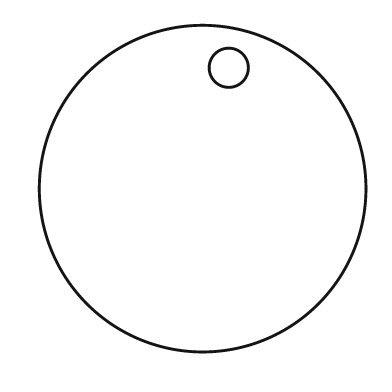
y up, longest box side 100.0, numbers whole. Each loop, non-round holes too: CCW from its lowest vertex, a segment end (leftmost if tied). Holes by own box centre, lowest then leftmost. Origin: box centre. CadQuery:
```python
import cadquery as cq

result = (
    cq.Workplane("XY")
    .moveTo(0.0, 0.0)
    .circle(50.0)
    .moveTo(8.0, 37.0)
    .circle(6.0)
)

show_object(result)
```